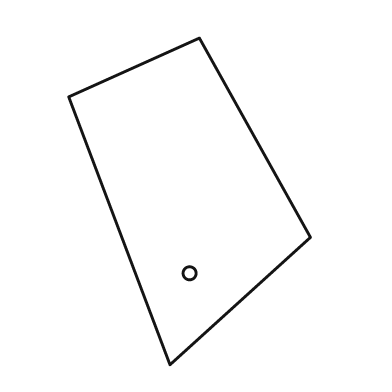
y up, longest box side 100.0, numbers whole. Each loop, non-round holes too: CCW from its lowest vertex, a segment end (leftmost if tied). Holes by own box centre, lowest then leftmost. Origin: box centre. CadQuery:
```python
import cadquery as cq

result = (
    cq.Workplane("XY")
    .moveTo(-6.0, -50.0)
    .lineTo(37.0, -11.0)
    .lineTo(3.0, 50.0)
    .lineTo(-37.0, 32.0)
    .close()
    .moveTo(0.0, -22.0)
    .circle(2.0)
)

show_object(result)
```